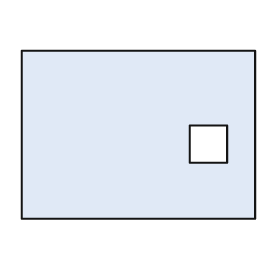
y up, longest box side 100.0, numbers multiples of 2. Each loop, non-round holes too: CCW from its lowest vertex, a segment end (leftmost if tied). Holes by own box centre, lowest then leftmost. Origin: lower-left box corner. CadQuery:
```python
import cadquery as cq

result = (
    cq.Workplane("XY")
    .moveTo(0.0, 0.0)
    .lineTo(100.0, 0.0)
    .lineTo(100.0, 72.0)
    .lineTo(0.0, 72.0)
    .close()
    .moveTo(72.0, 24.0)
    .lineTo(88.0, 24.0)
    .lineTo(88.0, 40.0)
    .lineTo(72.0, 40.0)
    .close()
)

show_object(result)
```